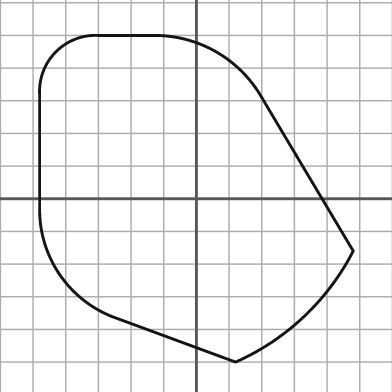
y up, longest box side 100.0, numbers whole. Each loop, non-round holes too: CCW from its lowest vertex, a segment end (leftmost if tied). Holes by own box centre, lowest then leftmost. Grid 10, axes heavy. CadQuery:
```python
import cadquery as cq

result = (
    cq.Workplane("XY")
    .moveTo(12.0, -50.0)
    .threePointArc((33.0, -36.0), (48.0, -16.0))
    .lineTo(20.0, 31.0)
    .threePointArc((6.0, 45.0), (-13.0, 50.0))
    .lineTo(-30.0, 50.0)
    .threePointArc((-43.0, 45.0), (-48.0, 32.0))
    .lineTo(-48.0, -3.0)
    .threePointArc((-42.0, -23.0), (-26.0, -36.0))
    .close()
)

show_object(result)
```